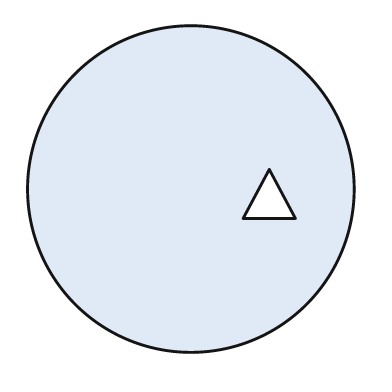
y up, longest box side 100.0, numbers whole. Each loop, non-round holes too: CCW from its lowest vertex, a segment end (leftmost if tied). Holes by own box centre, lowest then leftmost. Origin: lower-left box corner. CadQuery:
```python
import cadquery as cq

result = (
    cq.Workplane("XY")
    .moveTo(50.0, 50.0)
    .circle(50.0)
    .moveTo(66.0, 41.0)
    .lineTo(82.0, 41.0)
    .lineTo(74.0, 56.0)
    .close()
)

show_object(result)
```